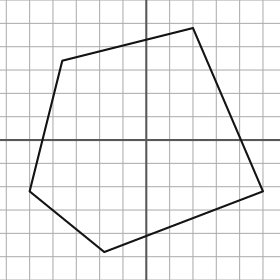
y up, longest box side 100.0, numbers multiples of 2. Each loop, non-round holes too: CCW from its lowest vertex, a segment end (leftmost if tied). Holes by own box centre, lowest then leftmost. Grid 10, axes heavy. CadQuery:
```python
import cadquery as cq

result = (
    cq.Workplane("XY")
    .moveTo(-18.0, -48.0)
    .lineTo(50.0, -22.0)
    .lineTo(20.0, 48.0)
    .lineTo(-36.0, 34.0)
    .lineTo(-50.0, -22.0)
    .close()
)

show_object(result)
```